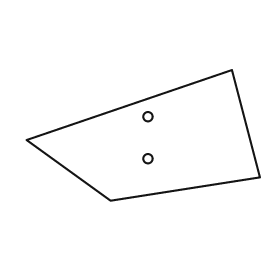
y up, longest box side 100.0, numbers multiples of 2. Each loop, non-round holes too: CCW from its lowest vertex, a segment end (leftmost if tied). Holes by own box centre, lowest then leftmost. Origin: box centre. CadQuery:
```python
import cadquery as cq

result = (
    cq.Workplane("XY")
    .moveTo(-14.0, -28.0)
    .lineTo(50.0, -18.0)
    .lineTo(38.0, 28.0)
    .lineTo(-50.0, -2.0)
    .close()
    .moveTo(2.0, -10.0)
    .circle(2.0)
    .moveTo(2.0, 8.0)
    .circle(2.0)
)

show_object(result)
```